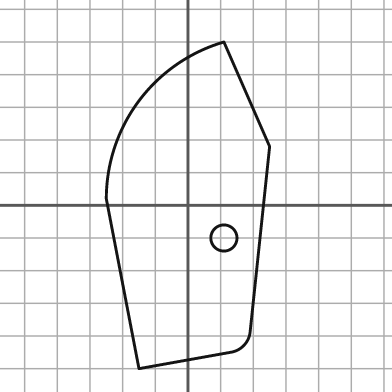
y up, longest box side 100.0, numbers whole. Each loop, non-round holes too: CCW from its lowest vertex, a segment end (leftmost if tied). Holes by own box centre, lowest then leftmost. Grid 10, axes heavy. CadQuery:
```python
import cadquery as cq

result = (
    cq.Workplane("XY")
    .moveTo(-15.0, -50.0)
    .lineTo(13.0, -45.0)
    .threePointArc((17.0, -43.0), (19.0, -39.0))
    .lineTo(25.0, 18.0)
    .lineTo(11.0, 50.0)
    .threePointArc((-15.0, 32.0), (-25.0, 2.0))
    .close()
    .moveTo(11.0, -10.0)
    .circle(4.0)
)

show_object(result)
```